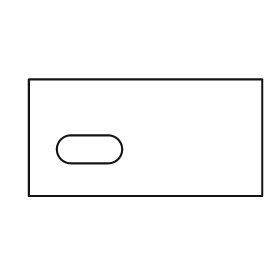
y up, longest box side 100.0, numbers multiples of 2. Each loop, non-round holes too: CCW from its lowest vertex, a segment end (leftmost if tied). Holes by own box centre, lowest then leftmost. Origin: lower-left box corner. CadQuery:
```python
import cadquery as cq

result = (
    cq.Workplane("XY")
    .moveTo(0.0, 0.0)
    .lineTo(100.0, 0.0)
    .lineTo(100.0, 50.0)
    .lineTo(0.0, 50.0)
    .close()
    .moveTo(18.0, 14.0)
    .lineTo(34.0, 14.0)
    .threePointArc((40.0, 20.0), (34.0, 26.0))
    .lineTo(18.0, 26.0)
    .threePointArc((12.0, 20.0), (18.0, 14.0))
    .close()
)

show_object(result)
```